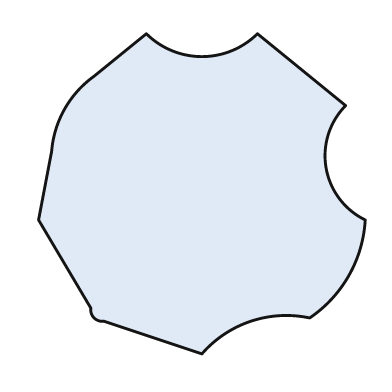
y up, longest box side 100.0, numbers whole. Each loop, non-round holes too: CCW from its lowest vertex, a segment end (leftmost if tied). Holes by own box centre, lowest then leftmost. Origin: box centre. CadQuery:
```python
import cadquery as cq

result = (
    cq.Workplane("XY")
    .moveTo(0.0, -49.0)
    .threePointArc((15.0, -39.0), (33.0, -38.0))
    .threePointArc((45.0, -25.0), (50.0, -8.0))
    .threePointArc((38.0, 8.0), (44.0, 27.0))
    .lineTo(17.0, 49.0)
    .threePointArc((0.0, 42.0), (-17.0, 49.0))
    .lineTo(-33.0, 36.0)
    .threePointArc((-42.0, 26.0), (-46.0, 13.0))
    .lineTo(-50.0, -8.0)
    .lineTo(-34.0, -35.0)
    .threePointArc((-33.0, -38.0), (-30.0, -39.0))
    .close()
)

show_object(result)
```